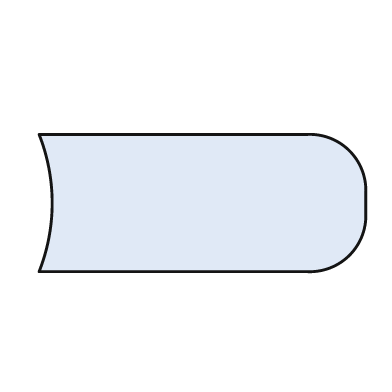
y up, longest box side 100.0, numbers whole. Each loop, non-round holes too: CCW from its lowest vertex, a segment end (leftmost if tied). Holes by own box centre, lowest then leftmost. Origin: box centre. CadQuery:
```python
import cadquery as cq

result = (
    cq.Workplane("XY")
    .moveTo(-50.0, -21.0)
    .lineTo(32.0, -21.0)
    .threePointArc((45.0, -16.0), (50.0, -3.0))
    .lineTo(50.0, 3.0)
    .threePointArc((45.0, 16.0), (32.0, 21.0))
    .lineTo(-50.0, 21.0)
    .threePointArc((-46.0, 0.0), (-50.0, -21.0))
    .close()
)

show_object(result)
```